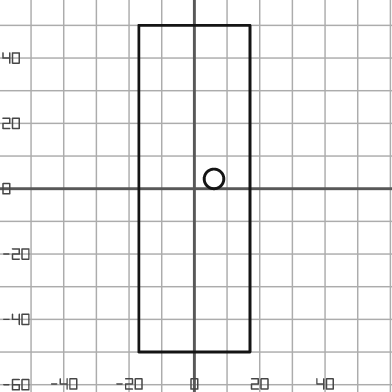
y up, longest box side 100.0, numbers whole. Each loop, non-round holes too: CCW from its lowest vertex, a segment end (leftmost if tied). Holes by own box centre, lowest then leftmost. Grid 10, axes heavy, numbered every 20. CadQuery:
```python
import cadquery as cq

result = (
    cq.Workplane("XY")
    .moveTo(-17.0, -50.0)
    .lineTo(17.0, -50.0)
    .lineTo(17.0, 50.0)
    .lineTo(-17.0, 50.0)
    .close()
    .moveTo(6.0, 3.0)
    .circle(3.0)
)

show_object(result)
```